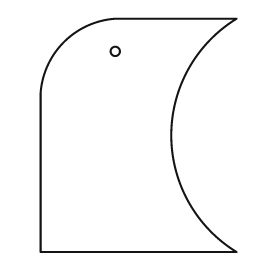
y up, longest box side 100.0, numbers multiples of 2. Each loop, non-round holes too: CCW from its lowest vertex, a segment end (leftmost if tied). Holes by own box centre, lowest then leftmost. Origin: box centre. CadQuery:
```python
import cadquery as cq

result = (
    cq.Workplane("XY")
    .moveTo(-42.0, -50.0)
    .lineTo(42.0, -50.0)
    .threePointArc((14.0, 0.0), (42.0, 50.0))
    .lineTo(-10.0, 50.0)
    .threePointArc((-32.0, 40.0), (-42.0, 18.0))
    .close()
    .moveTo(-10.0, 36.0)
    .circle(2.0)
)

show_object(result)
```